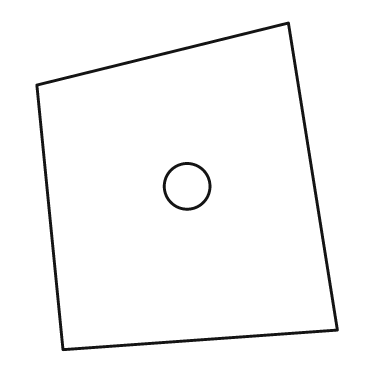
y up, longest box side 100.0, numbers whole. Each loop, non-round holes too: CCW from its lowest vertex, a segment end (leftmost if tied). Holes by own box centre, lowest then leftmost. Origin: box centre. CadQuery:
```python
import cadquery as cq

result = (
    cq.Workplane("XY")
    .moveTo(-38.0, -50.0)
    .lineTo(46.0, -44.0)
    .lineTo(31.0, 50.0)
    .lineTo(-46.0, 31.0)
    .close()
    .moveTo(0.0, 0.0)
    .circle(7.0)
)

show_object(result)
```